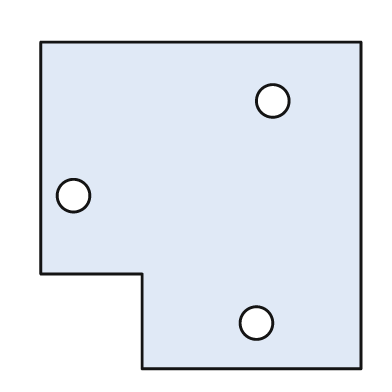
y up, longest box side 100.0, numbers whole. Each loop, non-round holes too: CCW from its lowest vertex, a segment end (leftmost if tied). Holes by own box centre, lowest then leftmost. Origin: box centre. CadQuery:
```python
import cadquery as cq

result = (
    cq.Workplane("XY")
    .moveTo(-18.0, -50.0)
    .lineTo(49.0, -50.0)
    .lineTo(49.0, 50.0)
    .lineTo(-49.0, 50.0)
    .lineTo(-49.0, -21.0)
    .lineTo(-18.0, -21.0)
    .close()
    .moveTo(17.0, -36.0)
    .circle(5.0)
    .moveTo(-39.0, 3.0)
    .circle(5.0)
    .moveTo(22.0, 32.0)
    .circle(5.0)
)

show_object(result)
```